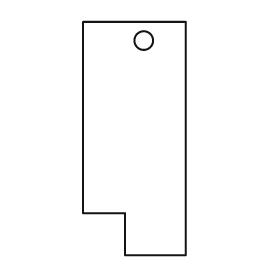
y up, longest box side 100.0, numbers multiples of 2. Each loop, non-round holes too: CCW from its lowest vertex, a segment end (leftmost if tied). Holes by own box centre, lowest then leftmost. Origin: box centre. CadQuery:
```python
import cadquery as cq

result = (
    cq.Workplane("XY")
    .moveTo(-4.0, -50.0)
    .lineTo(22.0, -50.0)
    .lineTo(22.0, 50.0)
    .lineTo(-22.0, 50.0)
    .lineTo(-22.0, -32.0)
    .lineTo(-4.0, -32.0)
    .close()
    .moveTo(4.0, 42.0)
    .circle(4.0)
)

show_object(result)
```